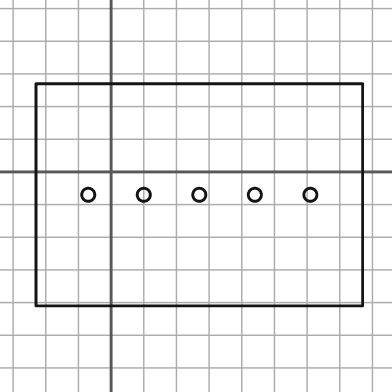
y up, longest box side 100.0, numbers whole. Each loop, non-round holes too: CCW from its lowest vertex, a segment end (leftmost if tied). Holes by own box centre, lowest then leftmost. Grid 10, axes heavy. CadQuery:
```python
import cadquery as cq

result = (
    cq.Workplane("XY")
    .moveTo(-23.0, -41.0)
    .lineTo(77.0, -41.0)
    .lineTo(77.0, 27.0)
    .lineTo(-23.0, 27.0)
    .close()
    .moveTo(-7.0, -7.0)
    .circle(2.0)
    .moveTo(10.0, -7.0)
    .circle(2.0)
    .moveTo(27.0, -7.0)
    .circle(2.0)
    .moveTo(44.0, -7.0)
    .circle(2.0)
    .moveTo(61.0, -7.0)
    .circle(2.0)
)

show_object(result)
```